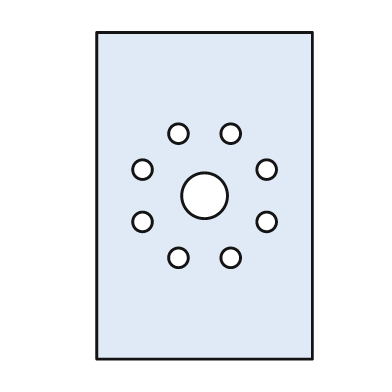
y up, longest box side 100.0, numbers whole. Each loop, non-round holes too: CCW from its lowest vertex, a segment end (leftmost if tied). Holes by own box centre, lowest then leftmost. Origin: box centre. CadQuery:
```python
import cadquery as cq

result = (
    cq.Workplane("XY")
    .moveTo(-33.0, -50.0)
    .lineTo(33.0, -50.0)
    .lineTo(33.0, 50.0)
    .lineTo(-33.0, 50.0)
    .close()
    .moveTo(-8.0, -19.0)
    .circle(3.0)
    .moveTo(8.0, -19.0)
    .circle(3.0)
    .moveTo(-19.0, -8.0)
    .circle(3.0)
    .moveTo(19.0, -8.0)
    .circle(3.0)
    .moveTo(0.0, 0.0)
    .circle(7.0)
    .moveTo(-19.0, 8.0)
    .circle(3.0)
    .moveTo(19.0, 8.0)
    .circle(3.0)
    .moveTo(-8.0, 19.0)
    .circle(3.0)
    .moveTo(8.0, 19.0)
    .circle(3.0)
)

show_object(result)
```